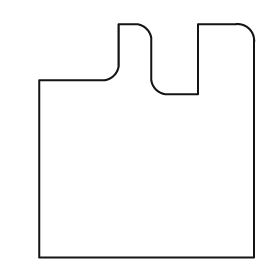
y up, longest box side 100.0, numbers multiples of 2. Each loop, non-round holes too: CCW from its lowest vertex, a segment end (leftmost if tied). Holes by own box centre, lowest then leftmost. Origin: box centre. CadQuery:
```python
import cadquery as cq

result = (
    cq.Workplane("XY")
    .moveTo(-46.0, -50.0)
    .lineTo(46.0, -50.0)
    .lineTo(46.0, 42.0)
    .threePointArc((44.0, 48.0), (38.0, 50.0))
    .lineTo(22.0, 50.0)
    .lineTo(22.0, 20.0)
    .lineTo(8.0, 20.0)
    .threePointArc((4.0, 22.0), (2.0, 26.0))
    .lineTo(2.0, 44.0)
    .threePointArc((0.0, 48.0), (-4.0, 50.0))
    .lineTo(-12.0, 50.0)
    .lineTo(-12.0, 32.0)
    .threePointArc((-14.0, 28.0), (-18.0, 26.0))
    .lineTo(-46.0, 26.0)
    .close()
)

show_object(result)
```